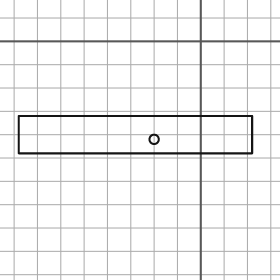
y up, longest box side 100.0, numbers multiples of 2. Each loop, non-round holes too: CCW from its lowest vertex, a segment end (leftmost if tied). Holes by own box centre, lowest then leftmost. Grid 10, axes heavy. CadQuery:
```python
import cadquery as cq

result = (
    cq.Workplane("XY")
    .moveTo(-78.0, -48.0)
    .lineTo(22.0, -48.0)
    .lineTo(22.0, -32.0)
    .lineTo(-78.0, -32.0)
    .close()
    .moveTo(-20.0, -42.0)
    .circle(2.0)
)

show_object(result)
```